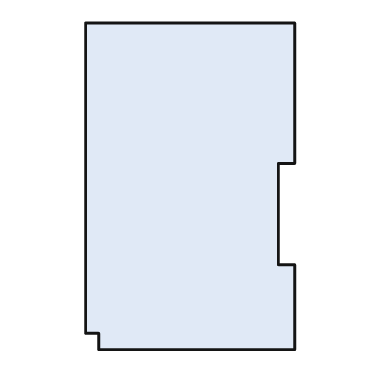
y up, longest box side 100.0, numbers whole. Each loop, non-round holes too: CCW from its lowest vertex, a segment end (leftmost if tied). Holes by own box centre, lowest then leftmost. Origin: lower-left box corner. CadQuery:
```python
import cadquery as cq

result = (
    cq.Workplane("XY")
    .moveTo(4.0, 0.0)
    .lineTo(64.0, 0.0)
    .lineTo(64.0, 26.0)
    .lineTo(59.0, 26.0)
    .lineTo(59.0, 57.0)
    .lineTo(64.0, 57.0)
    .lineTo(64.0, 100.0)
    .lineTo(0.0, 100.0)
    .lineTo(0.0, 5.0)
    .lineTo(4.0, 5.0)
    .close()
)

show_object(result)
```